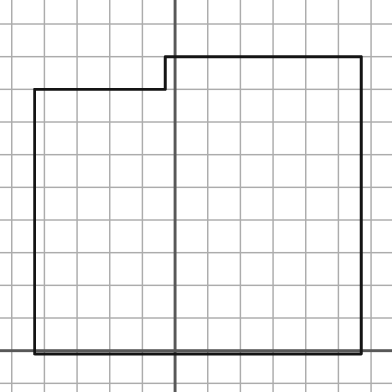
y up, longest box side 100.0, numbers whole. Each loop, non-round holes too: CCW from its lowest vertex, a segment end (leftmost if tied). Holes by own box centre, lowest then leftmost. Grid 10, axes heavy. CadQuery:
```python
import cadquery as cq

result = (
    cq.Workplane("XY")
    .moveTo(-43.0, -1.0)
    .lineTo(57.0, -1.0)
    .lineTo(57.0, 90.0)
    .lineTo(-3.0, 90.0)
    .lineTo(-3.0, 80.0)
    .lineTo(-43.0, 80.0)
    .close()
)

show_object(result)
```